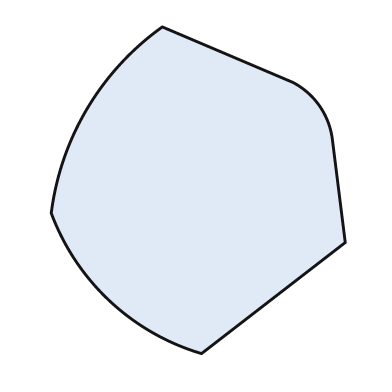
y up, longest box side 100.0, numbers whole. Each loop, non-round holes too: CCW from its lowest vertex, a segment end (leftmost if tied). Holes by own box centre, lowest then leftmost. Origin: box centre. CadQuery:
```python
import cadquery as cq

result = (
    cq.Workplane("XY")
    .moveTo(1.0, -50.0)
    .lineTo(45.0, -16.0)
    .lineTo(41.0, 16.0)
    .threePointArc((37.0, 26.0), (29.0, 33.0))
    .lineTo(-11.0, 50.0)
    .threePointArc((-34.0, 25.0), (-45.0, -7.0))
    .threePointArc((-27.0, -34.0), (1.0, -50.0))
    .close()
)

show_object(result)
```